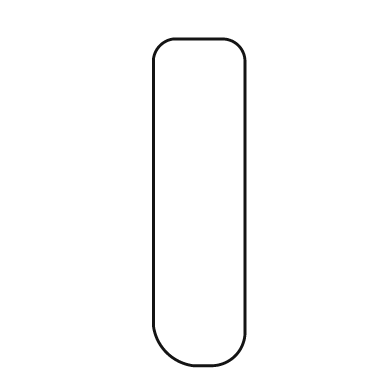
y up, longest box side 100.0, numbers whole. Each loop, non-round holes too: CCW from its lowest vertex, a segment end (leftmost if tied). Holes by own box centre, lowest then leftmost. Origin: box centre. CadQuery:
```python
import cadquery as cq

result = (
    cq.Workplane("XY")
    .moveTo(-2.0, -50.0)
    .lineTo(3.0, -50.0)
    .threePointArc((11.0, -47.0), (14.0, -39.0))
    .lineTo(14.0, 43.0)
    .threePointArc((12.0, 48.0), (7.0, 50.0))
    .lineTo(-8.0, 50.0)
    .threePointArc((-12.0, 48.0), (-14.0, 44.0))
    .lineTo(-14.0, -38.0)
    .threePointArc((-10.0, -46.0), (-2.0, -50.0))
    .close()
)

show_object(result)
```